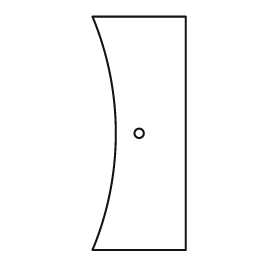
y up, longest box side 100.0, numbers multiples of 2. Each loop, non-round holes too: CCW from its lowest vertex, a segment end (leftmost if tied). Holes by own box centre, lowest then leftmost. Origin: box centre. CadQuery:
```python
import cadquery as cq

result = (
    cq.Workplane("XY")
    .moveTo(-20.0, -50.0)
    .lineTo(20.0, -50.0)
    .lineTo(20.0, 50.0)
    .lineTo(-20.0, 50.0)
    .threePointArc((-10.0, 0.0), (-20.0, -50.0))
    .close()
    .moveTo(0.0, 0.0)
    .circle(2.0)
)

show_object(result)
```